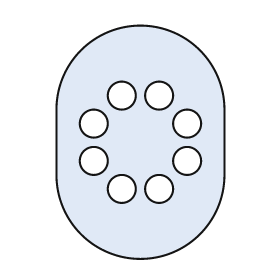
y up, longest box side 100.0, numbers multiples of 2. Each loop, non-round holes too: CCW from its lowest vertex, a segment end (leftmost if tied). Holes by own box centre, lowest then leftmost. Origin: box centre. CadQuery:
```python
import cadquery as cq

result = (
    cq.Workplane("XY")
    .moveTo(-36.0, -14.0)
    .threePointArc((0.0, -50.0), (36.0, -14.0))
    .lineTo(36.0, 14.0)
    .threePointArc((0.0, 50.0), (-36.0, 14.0))
    .close()
    .moveTo(-8.0, -20.0)
    .circle(6.0)
    .moveTo(8.0, -20.0)
    .circle(6.0)
    .moveTo(-20.0, -8.0)
    .circle(6.0)
    .moveTo(20.0, -8.0)
    .circle(6.0)
    .moveTo(-20.0, 8.0)
    .circle(6.0)
    .moveTo(20.0, 8.0)
    .circle(6.0)
    .moveTo(-8.0, 20.0)
    .circle(6.0)
    .moveTo(8.0, 20.0)
    .circle(6.0)
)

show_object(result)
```